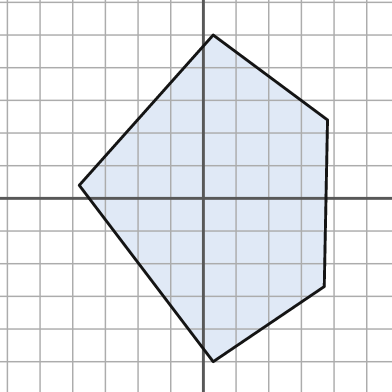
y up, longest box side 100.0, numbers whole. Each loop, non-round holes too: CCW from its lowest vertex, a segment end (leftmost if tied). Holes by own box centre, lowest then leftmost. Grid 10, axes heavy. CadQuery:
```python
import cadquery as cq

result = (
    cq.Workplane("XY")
    .moveTo(3.0, -50.0)
    .lineTo(37.0, -27.0)
    .lineTo(38.0, 24.0)
    .lineTo(3.0, 50.0)
    .lineTo(-38.0, 4.0)
    .close()
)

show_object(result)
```